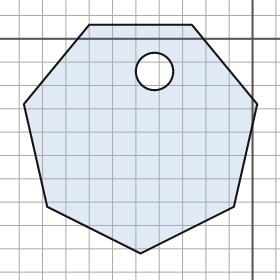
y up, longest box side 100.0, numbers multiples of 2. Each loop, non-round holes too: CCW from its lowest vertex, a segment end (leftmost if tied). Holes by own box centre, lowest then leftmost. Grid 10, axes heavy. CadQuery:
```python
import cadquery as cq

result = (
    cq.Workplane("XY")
    .moveTo(-48.0, -92.0)
    .lineTo(-8.0, -72.0)
    .lineTo(2.0, -28.0)
    .lineTo(-26.0, 6.0)
    .lineTo(-70.0, 6.0)
    .lineTo(-98.0, -28.0)
    .lineTo(-88.0, -72.0)
    .close()
    .moveTo(-42.0, -14.0)
    .circle(8.0)
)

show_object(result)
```